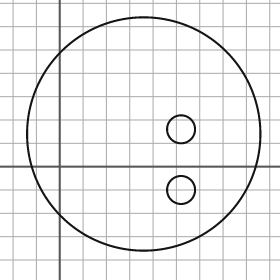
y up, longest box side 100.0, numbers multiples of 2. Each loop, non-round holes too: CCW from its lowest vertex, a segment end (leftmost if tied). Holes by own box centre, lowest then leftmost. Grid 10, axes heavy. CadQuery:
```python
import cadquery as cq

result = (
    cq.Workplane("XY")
    .moveTo(36.0, 14.0)
    .circle(50.0)
    .moveTo(52.0, -10.0)
    .circle(6.0)
    .moveTo(52.0, 16.0)
    .circle(6.0)
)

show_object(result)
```